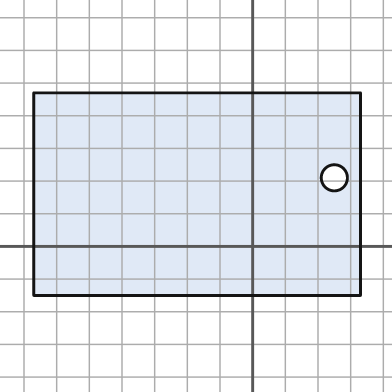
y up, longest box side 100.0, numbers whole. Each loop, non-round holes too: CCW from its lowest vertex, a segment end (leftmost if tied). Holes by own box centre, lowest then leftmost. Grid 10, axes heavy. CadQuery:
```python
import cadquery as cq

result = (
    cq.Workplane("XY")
    .moveTo(-67.0, -15.0)
    .lineTo(33.0, -15.0)
    .lineTo(33.0, 47.0)
    .lineTo(-67.0, 47.0)
    .close()
    .moveTo(25.0, 21.0)
    .circle(4.0)
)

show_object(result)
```